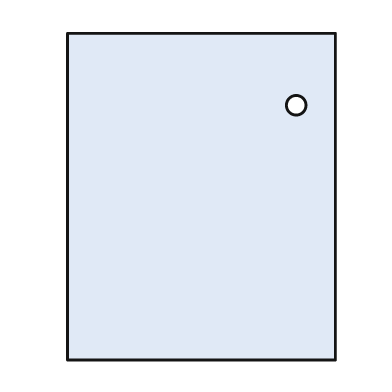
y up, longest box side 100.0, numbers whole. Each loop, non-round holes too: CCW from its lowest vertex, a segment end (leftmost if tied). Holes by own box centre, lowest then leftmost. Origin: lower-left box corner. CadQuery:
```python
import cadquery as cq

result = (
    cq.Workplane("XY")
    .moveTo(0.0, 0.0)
    .lineTo(82.0, 0.0)
    .lineTo(82.0, 100.0)
    .lineTo(0.0, 100.0)
    .close()
    .moveTo(70.0, 78.0)
    .circle(3.0)
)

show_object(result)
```